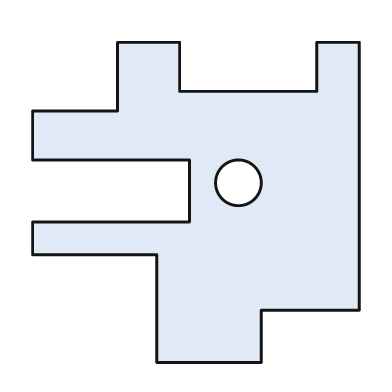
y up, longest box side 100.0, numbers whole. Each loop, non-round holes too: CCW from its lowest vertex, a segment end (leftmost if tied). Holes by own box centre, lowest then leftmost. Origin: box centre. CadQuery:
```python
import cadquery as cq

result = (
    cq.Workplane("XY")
    .moveTo(-12.0, -49.0)
    .lineTo(20.0, -49.0)
    .lineTo(20.0, -33.0)
    .lineTo(50.0, -33.0)
    .lineTo(50.0, 49.0)
    .lineTo(37.0, 49.0)
    .lineTo(37.0, 34.0)
    .lineTo(-5.0, 34.0)
    .lineTo(-5.0, 49.0)
    .lineTo(-24.0, 49.0)
    .lineTo(-24.0, 28.0)
    .lineTo(-50.0, 28.0)
    .lineTo(-50.0, 13.0)
    .lineTo(-2.0, 13.0)
    .lineTo(-2.0, -6.0)
    .lineTo(-50.0, -6.0)
    .lineTo(-50.0, -16.0)
    .lineTo(-12.0, -16.0)
    .close()
    .moveTo(13.0, 6.0)
    .circle(7.0)
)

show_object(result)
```